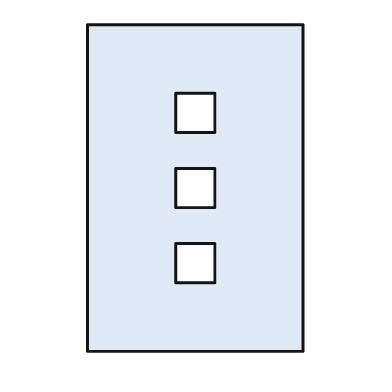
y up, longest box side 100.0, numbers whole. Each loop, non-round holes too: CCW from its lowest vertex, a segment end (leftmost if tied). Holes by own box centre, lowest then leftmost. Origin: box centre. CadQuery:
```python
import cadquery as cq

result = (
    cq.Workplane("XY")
    .moveTo(-33.0, -50.0)
    .lineTo(33.0, -50.0)
    .lineTo(33.0, 50.0)
    .lineTo(-33.0, 50.0)
    .close()
    .moveTo(-6.0, -29.0)
    .lineTo(6.0, -29.0)
    .lineTo(6.0, -17.0)
    .lineTo(-6.0, -17.0)
    .close()
    .moveTo(-6.0, -6.0)
    .lineTo(6.0, -6.0)
    .lineTo(6.0, 6.0)
    .lineTo(-6.0, 6.0)
    .close()
    .moveTo(-6.0, 17.0)
    .lineTo(6.0, 17.0)
    .lineTo(6.0, 29.0)
    .lineTo(-6.0, 29.0)
    .close()
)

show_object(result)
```